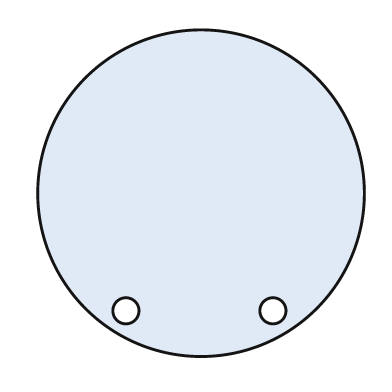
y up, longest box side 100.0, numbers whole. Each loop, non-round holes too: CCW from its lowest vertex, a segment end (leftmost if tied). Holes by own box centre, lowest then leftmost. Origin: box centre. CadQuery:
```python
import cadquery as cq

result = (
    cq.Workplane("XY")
    .moveTo(0.0, 0.0)
    .circle(50.0)
    .moveTo(-23.0, -36.0)
    .circle(4.0)
    .moveTo(22.0, -36.0)
    .circle(4.0)
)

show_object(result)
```